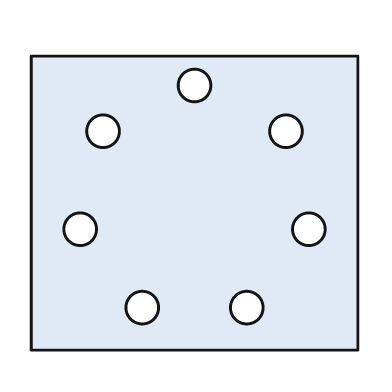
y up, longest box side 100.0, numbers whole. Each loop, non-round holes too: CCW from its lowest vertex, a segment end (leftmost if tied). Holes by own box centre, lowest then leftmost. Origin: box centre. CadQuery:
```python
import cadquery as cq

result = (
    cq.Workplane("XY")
    .moveTo(-50.0, -45.0)
    .lineTo(50.0, -45.0)
    .lineTo(50.0, 45.0)
    .lineTo(-50.0, 45.0)
    .close()
    .moveTo(-16.0, -32.0)
    .circle(5.0)
    .moveTo(16.0, -32.0)
    .circle(5.0)
    .moveTo(-35.0, -8.0)
    .circle(5.0)
    .moveTo(35.0, -8.0)
    .circle(5.0)
    .moveTo(-28.0, 22.0)
    .circle(5.0)
    .moveTo(28.0, 22.0)
    .circle(5.0)
    .moveTo(0.0, 36.0)
    .circle(5.0)
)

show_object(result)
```